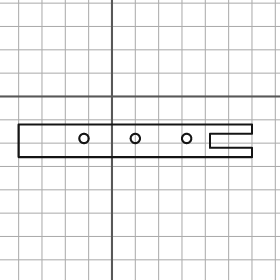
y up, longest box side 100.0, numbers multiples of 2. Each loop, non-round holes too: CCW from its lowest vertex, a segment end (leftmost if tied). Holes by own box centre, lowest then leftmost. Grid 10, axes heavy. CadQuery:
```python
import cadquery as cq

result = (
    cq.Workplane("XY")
    .moveTo(-40.0, -26.0)
    .lineTo(60.0, -26.0)
    .lineTo(60.0, -22.0)
    .lineTo(42.0, -22.0)
    .lineTo(42.0, -16.0)
    .lineTo(60.0, -16.0)
    .lineTo(60.0, -12.0)
    .lineTo(-40.0, -12.0)
    .close()
    .moveTo(-12.0, -18.0)
    .circle(2.0)
    .moveTo(10.0, -18.0)
    .circle(2.0)
    .moveTo(32.0, -18.0)
    .circle(2.0)
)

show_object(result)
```